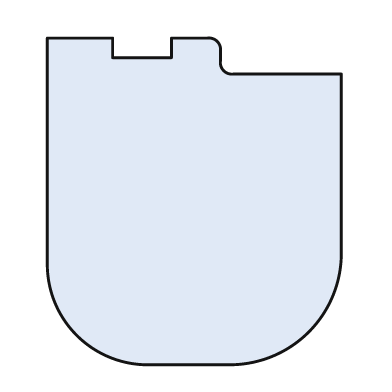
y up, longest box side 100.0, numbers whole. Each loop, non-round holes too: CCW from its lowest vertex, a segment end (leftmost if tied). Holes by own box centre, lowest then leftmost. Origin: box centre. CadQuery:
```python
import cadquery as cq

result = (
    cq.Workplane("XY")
    .moveTo(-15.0, -50.0)
    .lineTo(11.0, -50.0)
    .threePointArc((35.0, -40.0), (45.0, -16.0))
    .lineTo(45.0, 39.0)
    .lineTo(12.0, 39.0)
    .threePointArc((9.0, 40.0), (8.0, 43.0))
    .lineTo(8.0, 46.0)
    .threePointArc((7.0, 49.0), (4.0, 50.0))
    .lineTo(-7.0, 50.0)
    .lineTo(-7.0, 44.0)
    .lineTo(-25.0, 44.0)
    .lineTo(-25.0, 50.0)
    .lineTo(-45.0, 50.0)
    .lineTo(-45.0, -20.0)
    .threePointArc((-36.0, -41.0), (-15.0, -50.0))
    .close()
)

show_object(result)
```